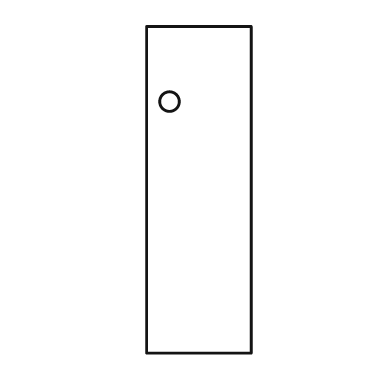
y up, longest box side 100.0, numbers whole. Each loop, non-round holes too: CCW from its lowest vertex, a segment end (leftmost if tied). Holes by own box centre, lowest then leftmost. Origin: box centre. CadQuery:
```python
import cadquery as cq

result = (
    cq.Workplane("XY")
    .moveTo(-16.0, -50.0)
    .lineTo(16.0, -50.0)
    .lineTo(16.0, 50.0)
    .lineTo(-16.0, 50.0)
    .close()
    .moveTo(-9.0, 27.0)
    .circle(3.0)
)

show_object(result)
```